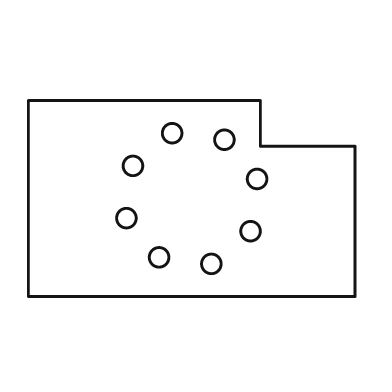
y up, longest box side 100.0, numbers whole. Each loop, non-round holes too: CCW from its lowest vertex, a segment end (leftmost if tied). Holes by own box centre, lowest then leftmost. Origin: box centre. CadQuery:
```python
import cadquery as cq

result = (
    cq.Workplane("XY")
    .moveTo(-50.0, -30.0)
    .lineTo(50.0, -30.0)
    .lineTo(50.0, 16.0)
    .lineTo(21.0, 16.0)
    .lineTo(21.0, 30.0)
    .lineTo(-50.0, 30.0)
    .close()
    .moveTo(6.0, -20.0)
    .circle(3.0)
    .moveTo(-10.0, -18.0)
    .circle(3.0)
    .moveTo(18.0, -10.0)
    .circle(3.0)
    .moveTo(-20.0, -6.0)
    .circle(3.0)
    .moveTo(20.0, 6.0)
    .circle(3.0)
    .moveTo(-18.0, 10.0)
    .circle(3.0)
    .moveTo(10.0, 18.0)
    .circle(3.0)
    .moveTo(-6.0, 20.0)
    .circle(3.0)
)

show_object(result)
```